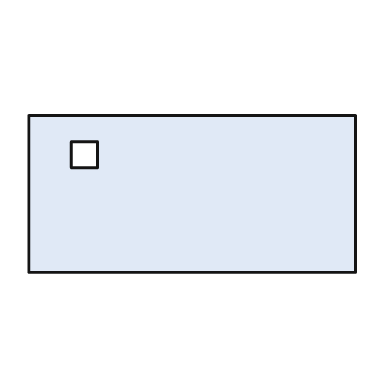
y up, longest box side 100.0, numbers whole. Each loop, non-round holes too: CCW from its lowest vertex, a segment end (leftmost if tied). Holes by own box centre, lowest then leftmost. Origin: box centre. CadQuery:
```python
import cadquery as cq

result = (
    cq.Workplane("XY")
    .moveTo(-50.0, -24.0)
    .lineTo(50.0, -24.0)
    .lineTo(50.0, 24.0)
    .lineTo(-50.0, 24.0)
    .close()
    .moveTo(-37.0, 8.0)
    .lineTo(-29.0, 8.0)
    .lineTo(-29.0, 16.0)
    .lineTo(-37.0, 16.0)
    .close()
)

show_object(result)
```